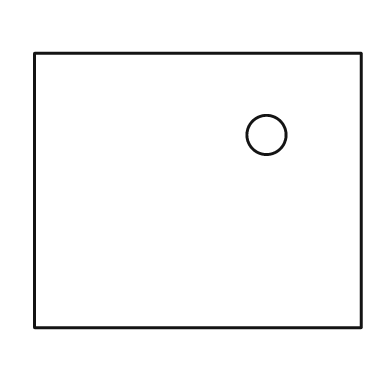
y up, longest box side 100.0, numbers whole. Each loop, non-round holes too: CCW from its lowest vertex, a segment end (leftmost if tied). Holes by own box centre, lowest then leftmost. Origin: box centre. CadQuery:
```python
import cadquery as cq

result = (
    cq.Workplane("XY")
    .moveTo(-50.0, -42.0)
    .lineTo(50.0, -42.0)
    .lineTo(50.0, 42.0)
    .lineTo(-50.0, 42.0)
    .close()
    .moveTo(21.0, 17.0)
    .circle(6.0)
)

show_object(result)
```